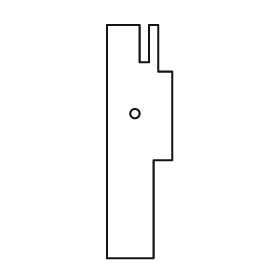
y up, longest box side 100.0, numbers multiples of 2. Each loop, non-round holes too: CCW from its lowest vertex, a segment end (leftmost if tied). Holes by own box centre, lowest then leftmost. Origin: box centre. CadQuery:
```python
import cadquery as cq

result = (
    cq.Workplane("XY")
    .moveTo(-14.0, -50.0)
    .lineTo(6.0, -50.0)
    .lineTo(6.0, -8.0)
    .lineTo(14.0, -8.0)
    .lineTo(14.0, 30.0)
    .lineTo(8.0, 30.0)
    .lineTo(8.0, 50.0)
    .lineTo(4.0, 50.0)
    .lineTo(4.0, 34.0)
    .lineTo(0.0, 34.0)
    .lineTo(0.0, 50.0)
    .lineTo(-14.0, 50.0)
    .close()
    .moveTo(-2.0, 12.0)
    .circle(2.0)
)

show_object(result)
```